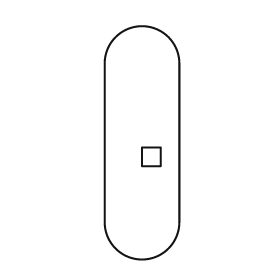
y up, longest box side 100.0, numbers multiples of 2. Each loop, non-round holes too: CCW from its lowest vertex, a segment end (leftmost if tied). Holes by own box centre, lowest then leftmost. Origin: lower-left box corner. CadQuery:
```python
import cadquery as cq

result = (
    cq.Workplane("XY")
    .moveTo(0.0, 16.0)
    .threePointArc((16.0, 0.0), (32.0, 16.0))
    .lineTo(32.0, 84.0)
    .threePointArc((16.0, 100.0), (0.0, 84.0))
    .close()
    .moveTo(16.0, 40.0)
    .lineTo(24.0, 40.0)
    .lineTo(24.0, 48.0)
    .lineTo(16.0, 48.0)
    .close()
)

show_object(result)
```